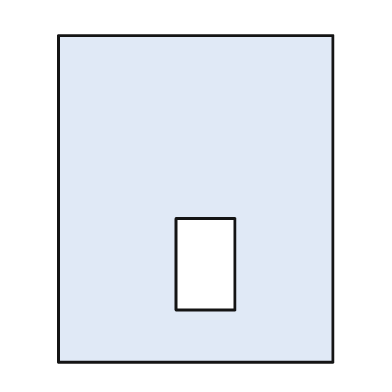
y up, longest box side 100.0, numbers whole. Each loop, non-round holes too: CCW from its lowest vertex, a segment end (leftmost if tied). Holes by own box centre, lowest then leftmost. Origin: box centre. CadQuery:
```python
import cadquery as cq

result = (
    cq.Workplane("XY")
    .moveTo(-42.0, -50.0)
    .lineTo(42.0, -50.0)
    .lineTo(42.0, 50.0)
    .lineTo(-42.0, 50.0)
    .close()
    .moveTo(-6.0, -34.0)
    .lineTo(12.0, -34.0)
    .lineTo(12.0, -6.0)
    .lineTo(-6.0, -6.0)
    .close()
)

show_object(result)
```